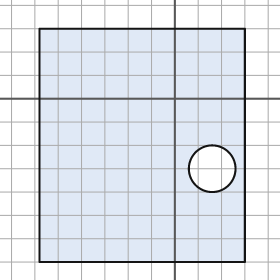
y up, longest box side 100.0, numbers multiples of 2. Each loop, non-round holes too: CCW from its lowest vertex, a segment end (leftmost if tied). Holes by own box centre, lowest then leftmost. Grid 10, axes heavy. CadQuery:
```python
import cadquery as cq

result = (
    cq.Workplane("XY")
    .moveTo(-58.0, -70.0)
    .lineTo(30.0, -70.0)
    .lineTo(30.0, 30.0)
    .lineTo(-58.0, 30.0)
    .close()
    .moveTo(16.0, -30.0)
    .circle(10.0)
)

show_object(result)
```